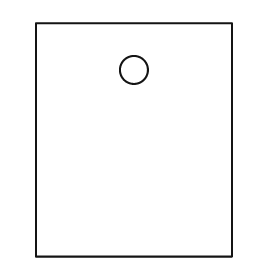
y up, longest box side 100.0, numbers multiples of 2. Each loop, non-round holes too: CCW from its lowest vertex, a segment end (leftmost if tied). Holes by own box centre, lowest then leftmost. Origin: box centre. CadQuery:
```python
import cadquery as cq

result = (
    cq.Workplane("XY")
    .moveTo(-42.0, -50.0)
    .lineTo(42.0, -50.0)
    .lineTo(42.0, 50.0)
    .lineTo(-42.0, 50.0)
    .close()
    .moveTo(0.0, 30.0)
    .circle(6.0)
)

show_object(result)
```